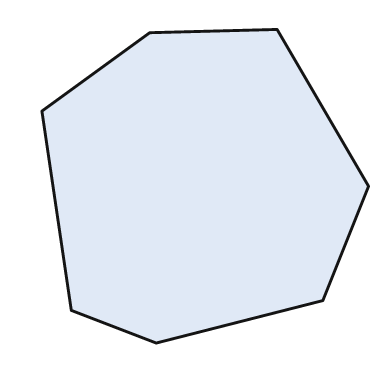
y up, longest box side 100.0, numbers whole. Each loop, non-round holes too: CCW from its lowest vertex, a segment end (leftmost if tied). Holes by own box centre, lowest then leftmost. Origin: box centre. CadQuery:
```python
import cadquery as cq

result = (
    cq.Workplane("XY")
    .moveTo(-15.0, -48.0)
    .lineTo(36.0, -35.0)
    .lineTo(50.0, 0.0)
    .lineTo(22.0, 48.0)
    .lineTo(-17.0, 47.0)
    .lineTo(-50.0, 23.0)
    .lineTo(-41.0, -38.0)
    .close()
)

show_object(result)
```